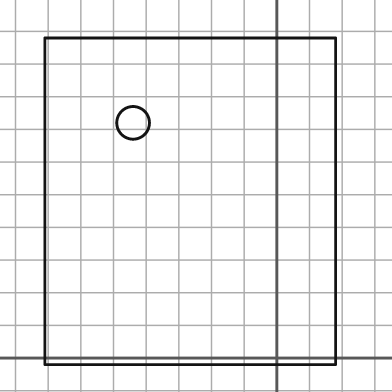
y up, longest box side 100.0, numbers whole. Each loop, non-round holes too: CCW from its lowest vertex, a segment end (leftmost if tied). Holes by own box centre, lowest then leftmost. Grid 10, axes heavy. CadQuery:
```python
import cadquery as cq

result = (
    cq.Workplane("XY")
    .moveTo(-71.0, -2.0)
    .lineTo(18.0, -2.0)
    .lineTo(18.0, 98.0)
    .lineTo(-71.0, 98.0)
    .close()
    .moveTo(-44.0, 72.0)
    .circle(5.0)
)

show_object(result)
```